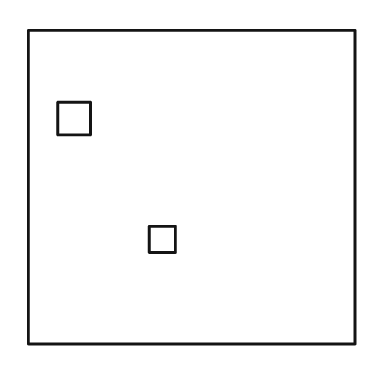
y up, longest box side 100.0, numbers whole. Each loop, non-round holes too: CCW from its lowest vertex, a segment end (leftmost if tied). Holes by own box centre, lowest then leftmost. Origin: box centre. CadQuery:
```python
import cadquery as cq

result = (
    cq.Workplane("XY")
    .moveTo(-50.0, -48.0)
    .lineTo(50.0, -48.0)
    .lineTo(50.0, 48.0)
    .lineTo(-50.0, 48.0)
    .close()
    .moveTo(-13.0, -20.0)
    .lineTo(-5.0, -20.0)
    .lineTo(-5.0, -12.0)
    .lineTo(-13.0, -12.0)
    .close()
    .moveTo(-41.0, 16.0)
    .lineTo(-31.0, 16.0)
    .lineTo(-31.0, 26.0)
    .lineTo(-41.0, 26.0)
    .close()
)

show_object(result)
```